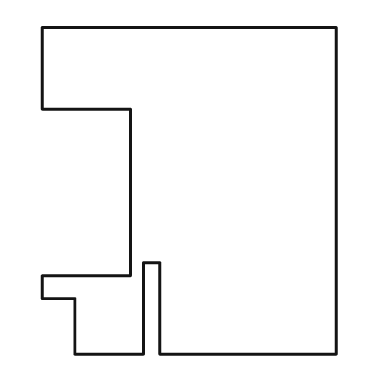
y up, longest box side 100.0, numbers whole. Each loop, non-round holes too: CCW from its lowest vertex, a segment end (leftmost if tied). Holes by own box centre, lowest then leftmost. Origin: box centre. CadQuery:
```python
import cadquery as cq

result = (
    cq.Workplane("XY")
    .moveTo(-35.0, -50.0)
    .lineTo(-14.0, -50.0)
    .lineTo(-14.0, -22.0)
    .lineTo(-9.0, -22.0)
    .lineTo(-9.0, -50.0)
    .lineTo(45.0, -50.0)
    .lineTo(45.0, 50.0)
    .lineTo(-45.0, 50.0)
    .lineTo(-45.0, 25.0)
    .lineTo(-18.0, 25.0)
    .lineTo(-18.0, -26.0)
    .lineTo(-45.0, -26.0)
    .lineTo(-45.0, -33.0)
    .lineTo(-35.0, -33.0)
    .close()
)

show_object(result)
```